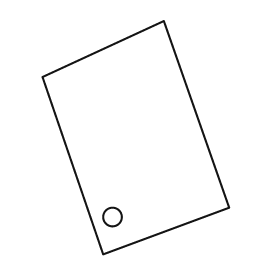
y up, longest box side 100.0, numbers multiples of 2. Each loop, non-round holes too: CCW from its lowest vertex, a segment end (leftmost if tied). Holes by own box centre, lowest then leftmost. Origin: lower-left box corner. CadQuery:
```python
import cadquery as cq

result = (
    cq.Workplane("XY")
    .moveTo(26.0, 0.0)
    .lineTo(80.0, 20.0)
    .lineTo(52.0, 100.0)
    .lineTo(0.0, 76.0)
    .close()
    .moveTo(30.0, 16.0)
    .circle(4.0)
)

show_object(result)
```